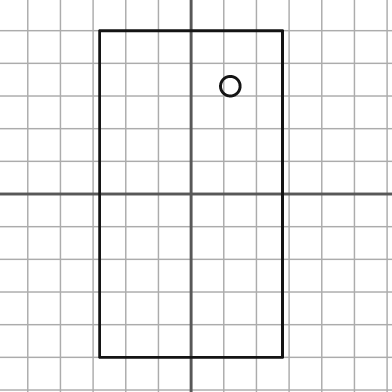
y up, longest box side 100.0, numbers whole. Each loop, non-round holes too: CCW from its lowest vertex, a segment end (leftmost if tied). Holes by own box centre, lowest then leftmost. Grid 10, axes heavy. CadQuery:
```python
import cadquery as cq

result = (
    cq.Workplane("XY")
    .moveTo(-28.0, -50.0)
    .lineTo(28.0, -50.0)
    .lineTo(28.0, 50.0)
    .lineTo(-28.0, 50.0)
    .close()
    .moveTo(12.0, 33.0)
    .circle(3.0)
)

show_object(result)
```